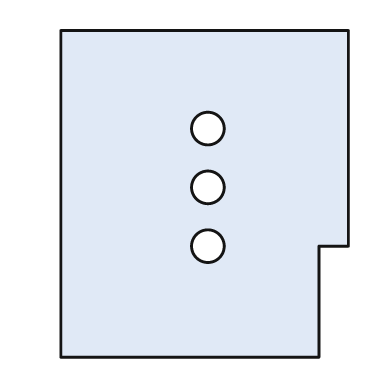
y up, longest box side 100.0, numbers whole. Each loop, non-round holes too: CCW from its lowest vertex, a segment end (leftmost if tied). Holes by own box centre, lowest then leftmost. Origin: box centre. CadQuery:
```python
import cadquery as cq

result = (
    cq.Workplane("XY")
    .moveTo(-44.0, -50.0)
    .lineTo(35.0, -50.0)
    .lineTo(35.0, -16.0)
    .lineTo(44.0, -16.0)
    .lineTo(44.0, 50.0)
    .lineTo(-44.0, 50.0)
    .close()
    .moveTo(1.0, -16.0)
    .circle(5.0)
    .moveTo(1.0, 2.0)
    .circle(5.0)
    .moveTo(1.0, 20.0)
    .circle(5.0)
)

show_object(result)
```